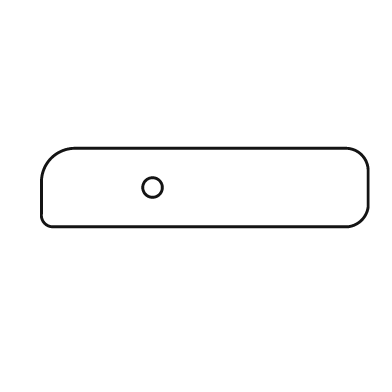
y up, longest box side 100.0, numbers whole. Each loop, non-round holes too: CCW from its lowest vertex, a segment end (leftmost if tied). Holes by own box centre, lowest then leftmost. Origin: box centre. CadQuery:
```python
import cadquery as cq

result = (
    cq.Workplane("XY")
    .moveTo(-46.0, -12.0)
    .lineTo(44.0, -12.0)
    .threePointArc((48.0, -10.0), (50.0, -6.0))
    .lineTo(50.0, 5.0)
    .threePointArc((48.0, 10.0), (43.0, 12.0))
    .lineTo(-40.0, 12.0)
    .threePointArc((-47.0, 9.0), (-50.0, 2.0))
    .lineTo(-50.0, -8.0)
    .threePointArc((-49.0, -11.0), (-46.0, -12.0))
    .close()
    .moveTo(-16.0, 0.0)
    .circle(3.0)
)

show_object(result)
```